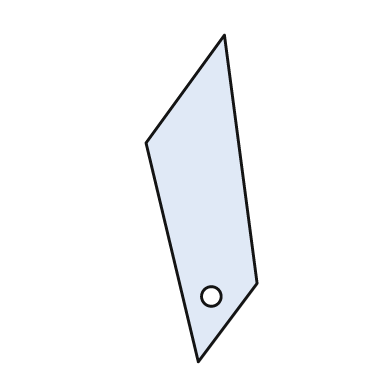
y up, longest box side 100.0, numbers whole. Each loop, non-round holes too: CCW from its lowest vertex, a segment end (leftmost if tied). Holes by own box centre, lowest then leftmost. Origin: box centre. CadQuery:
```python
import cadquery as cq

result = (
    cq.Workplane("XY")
    .moveTo(-1.0, -50.0)
    .lineTo(17.0, -26.0)
    .lineTo(7.0, 50.0)
    .lineTo(-17.0, 17.0)
    .close()
    .moveTo(3.0, -30.0)
    .circle(3.0)
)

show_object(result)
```